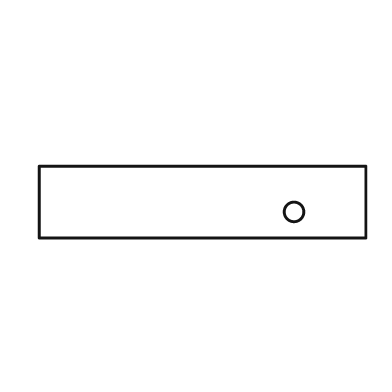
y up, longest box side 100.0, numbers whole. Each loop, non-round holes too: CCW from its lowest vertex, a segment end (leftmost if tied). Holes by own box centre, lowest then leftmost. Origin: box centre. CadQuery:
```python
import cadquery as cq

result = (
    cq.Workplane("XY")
    .moveTo(-50.0, -11.0)
    .lineTo(50.0, -11.0)
    .lineTo(50.0, 11.0)
    .lineTo(-50.0, 11.0)
    .close()
    .moveTo(28.0, -3.0)
    .circle(3.0)
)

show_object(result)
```